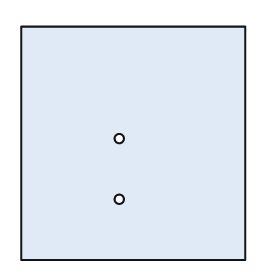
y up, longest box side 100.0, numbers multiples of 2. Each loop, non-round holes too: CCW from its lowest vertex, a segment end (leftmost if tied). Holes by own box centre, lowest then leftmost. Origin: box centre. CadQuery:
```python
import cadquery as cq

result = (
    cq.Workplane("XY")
    .moveTo(-48.0, -50.0)
    .lineTo(48.0, -50.0)
    .lineTo(48.0, 50.0)
    .lineTo(-48.0, 50.0)
    .close()
    .moveTo(-6.0, -24.0)
    .circle(2.0)
    .moveTo(-6.0, 2.0)
    .circle(2.0)
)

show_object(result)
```